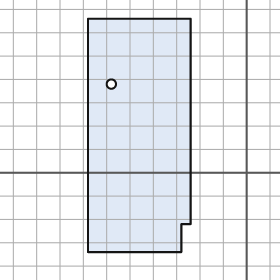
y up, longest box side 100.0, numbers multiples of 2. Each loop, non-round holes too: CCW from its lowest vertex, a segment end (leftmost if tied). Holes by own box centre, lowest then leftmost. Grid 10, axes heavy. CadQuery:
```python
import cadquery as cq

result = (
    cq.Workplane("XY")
    .moveTo(-68.0, -34.0)
    .lineTo(-28.0, -34.0)
    .lineTo(-28.0, -22.0)
    .lineTo(-24.0, -22.0)
    .lineTo(-24.0, 66.0)
    .lineTo(-68.0, 66.0)
    .close()
    .moveTo(-58.0, 38.0)
    .circle(2.0)
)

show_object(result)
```